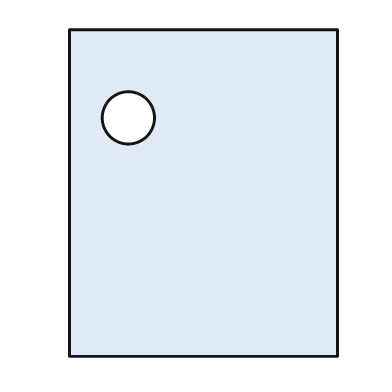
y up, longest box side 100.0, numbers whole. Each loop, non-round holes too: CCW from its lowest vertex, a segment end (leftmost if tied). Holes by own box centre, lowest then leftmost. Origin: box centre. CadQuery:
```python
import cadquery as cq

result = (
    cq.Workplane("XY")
    .moveTo(-41.0, -50.0)
    .lineTo(41.0, -50.0)
    .lineTo(41.0, 50.0)
    .lineTo(-41.0, 50.0)
    .close()
    .moveTo(-23.0, 23.0)
    .circle(8.0)
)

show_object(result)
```